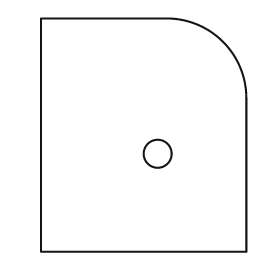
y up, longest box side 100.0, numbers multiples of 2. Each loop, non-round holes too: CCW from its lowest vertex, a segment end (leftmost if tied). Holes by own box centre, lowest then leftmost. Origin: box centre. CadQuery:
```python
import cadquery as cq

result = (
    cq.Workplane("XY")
    .moveTo(-44.0, -50.0)
    .lineTo(44.0, -50.0)
    .lineTo(44.0, 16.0)
    .threePointArc((34.0, 40.0), (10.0, 50.0))
    .lineTo(-44.0, 50.0)
    .close()
    .moveTo(6.0, -8.0)
    .circle(6.0)
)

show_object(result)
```